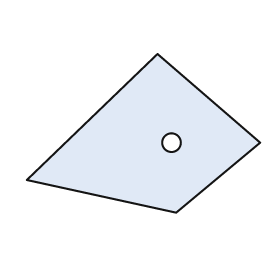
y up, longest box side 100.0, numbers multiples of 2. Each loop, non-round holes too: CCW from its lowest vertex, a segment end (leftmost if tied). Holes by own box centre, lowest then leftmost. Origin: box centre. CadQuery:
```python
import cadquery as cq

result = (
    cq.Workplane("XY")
    .moveTo(14.0, -34.0)
    .lineTo(50.0, -4.0)
    .lineTo(6.0, 34.0)
    .lineTo(-50.0, -20.0)
    .close()
    .moveTo(12.0, -4.0)
    .circle(4.0)
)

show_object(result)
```